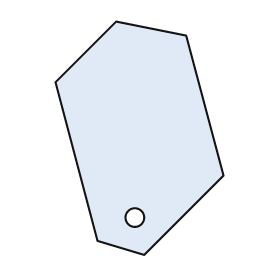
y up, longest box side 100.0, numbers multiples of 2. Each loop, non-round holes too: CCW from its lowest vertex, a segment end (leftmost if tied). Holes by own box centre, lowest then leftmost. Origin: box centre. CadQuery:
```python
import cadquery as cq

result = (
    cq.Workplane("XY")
    .moveTo(2.0, -50.0)
    .lineTo(36.0, -16.0)
    .lineTo(20.0, 44.0)
    .lineTo(-10.0, 50.0)
    .lineTo(-36.0, 24.0)
    .lineTo(-18.0, -44.0)
    .close()
    .moveTo(-2.0, -34.0)
    .circle(4.0)
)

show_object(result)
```